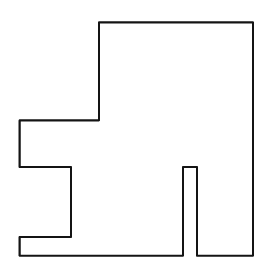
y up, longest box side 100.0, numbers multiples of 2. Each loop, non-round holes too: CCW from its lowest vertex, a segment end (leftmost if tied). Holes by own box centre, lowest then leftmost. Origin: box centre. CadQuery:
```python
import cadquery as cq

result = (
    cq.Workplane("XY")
    .moveTo(-50.0, -50.0)
    .lineTo(20.0, -50.0)
    .lineTo(20.0, -12.0)
    .lineTo(26.0, -12.0)
    .lineTo(26.0, -50.0)
    .lineTo(50.0, -50.0)
    .lineTo(50.0, 50.0)
    .lineTo(-16.0, 50.0)
    .lineTo(-16.0, 8.0)
    .lineTo(-50.0, 8.0)
    .lineTo(-50.0, -12.0)
    .lineTo(-28.0, -12.0)
    .lineTo(-28.0, -42.0)
    .lineTo(-50.0, -42.0)
    .close()
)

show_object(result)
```